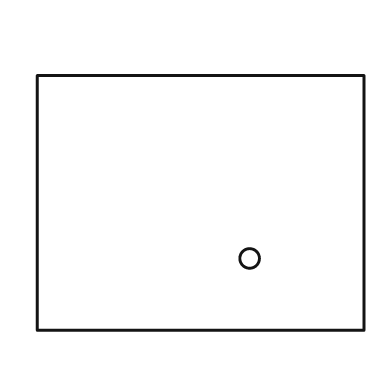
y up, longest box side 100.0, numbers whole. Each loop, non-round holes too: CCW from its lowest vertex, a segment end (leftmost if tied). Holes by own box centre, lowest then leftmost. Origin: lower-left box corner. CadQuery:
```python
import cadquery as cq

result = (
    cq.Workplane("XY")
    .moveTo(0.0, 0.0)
    .lineTo(100.0, 0.0)
    .lineTo(100.0, 78.0)
    .lineTo(0.0, 78.0)
    .close()
    .moveTo(65.0, 22.0)
    .circle(3.0)
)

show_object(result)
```